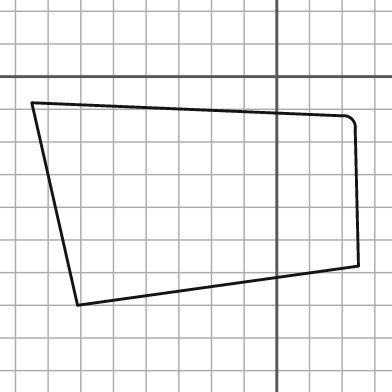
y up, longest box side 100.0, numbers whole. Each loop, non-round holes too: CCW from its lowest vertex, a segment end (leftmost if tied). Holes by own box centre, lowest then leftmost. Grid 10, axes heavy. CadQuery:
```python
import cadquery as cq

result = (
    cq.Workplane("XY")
    .moveTo(-61.0, -70.0)
    .lineTo(25.0, -58.0)
    .lineTo(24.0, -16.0)
    .threePointArc((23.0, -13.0), (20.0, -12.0))
    .lineTo(-75.0, -8.0)
    .close()
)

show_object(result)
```